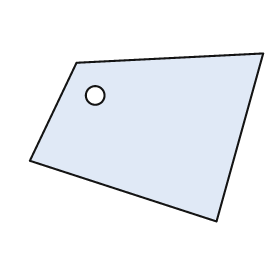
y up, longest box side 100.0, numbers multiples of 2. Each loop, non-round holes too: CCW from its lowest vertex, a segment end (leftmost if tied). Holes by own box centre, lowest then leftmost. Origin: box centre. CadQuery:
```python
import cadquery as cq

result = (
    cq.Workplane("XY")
    .moveTo(30.0, -36.0)
    .lineTo(50.0, 36.0)
    .lineTo(-30.0, 32.0)
    .lineTo(-50.0, -10.0)
    .close()
    .moveTo(-22.0, 18.0)
    .circle(4.0)
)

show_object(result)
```